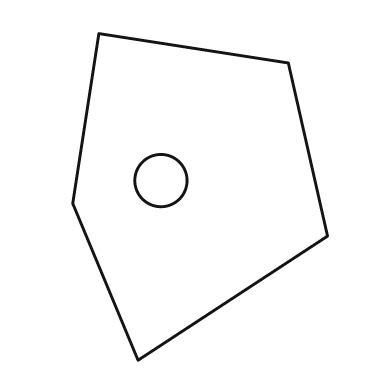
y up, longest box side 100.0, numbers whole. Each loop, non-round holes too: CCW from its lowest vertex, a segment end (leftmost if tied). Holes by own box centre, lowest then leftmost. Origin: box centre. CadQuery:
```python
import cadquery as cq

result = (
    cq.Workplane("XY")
    .moveTo(-19.0, -50.0)
    .lineTo(39.0, -12.0)
    .lineTo(27.0, 41.0)
    .lineTo(-31.0, 50.0)
    .lineTo(-39.0, -2.0)
    .close()
    .moveTo(-12.0, 5.0)
    .circle(8.0)
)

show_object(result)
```